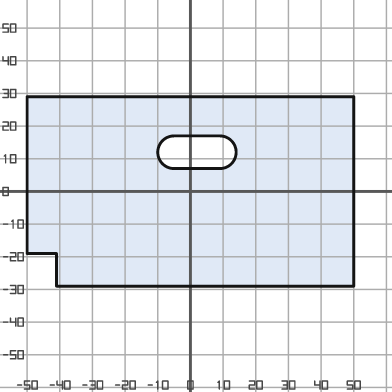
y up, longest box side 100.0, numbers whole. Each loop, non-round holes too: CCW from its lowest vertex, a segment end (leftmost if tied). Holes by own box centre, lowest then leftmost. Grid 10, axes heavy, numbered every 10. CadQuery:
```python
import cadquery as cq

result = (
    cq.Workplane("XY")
    .moveTo(-41.0, -29.0)
    .lineTo(50.0, -29.0)
    .lineTo(50.0, 29.0)
    .lineTo(-50.0, 29.0)
    .lineTo(-50.0, -19.0)
    .lineTo(-41.0, -19.0)
    .close()
    .moveTo(-5.0, 7.0)
    .lineTo(9.0, 7.0)
    .threePointArc((14.0, 12.0), (9.0, 17.0))
    .lineTo(-5.0, 17.0)
    .threePointArc((-10.0, 12.0), (-5.0, 7.0))
    .close()
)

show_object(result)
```